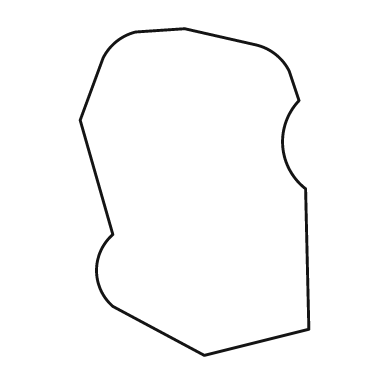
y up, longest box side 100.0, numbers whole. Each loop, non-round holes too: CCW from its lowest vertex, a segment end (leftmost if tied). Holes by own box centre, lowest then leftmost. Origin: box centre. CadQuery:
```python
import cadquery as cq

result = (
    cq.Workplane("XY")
    .moveTo(3.0, -50.0)
    .lineTo(35.0, -42.0)
    .lineTo(34.0, 1.0)
    .threePointArc((27.0, 14.0), (32.0, 28.0))
    .lineTo(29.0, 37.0)
    .threePointArc((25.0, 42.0), (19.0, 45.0))
    .lineTo(-3.0, 50.0)
    .lineTo(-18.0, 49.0)
    .threePointArc((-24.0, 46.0), (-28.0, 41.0))
    .lineTo(-35.0, 22.0)
    .lineTo(-25.0, -13.0)
    .threePointArc((-30.0, -24.0), (-25.0, -35.0))
    .close()
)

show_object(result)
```